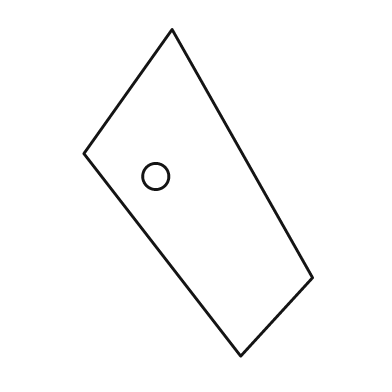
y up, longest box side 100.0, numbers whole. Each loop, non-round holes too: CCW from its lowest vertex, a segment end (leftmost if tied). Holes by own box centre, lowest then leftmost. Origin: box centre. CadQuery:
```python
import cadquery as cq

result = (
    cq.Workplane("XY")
    .moveTo(13.0, -50.0)
    .lineTo(35.0, -26.0)
    .lineTo(-8.0, 50.0)
    .lineTo(-35.0, 12.0)
    .close()
    .moveTo(-13.0, 5.0)
    .circle(4.0)
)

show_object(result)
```